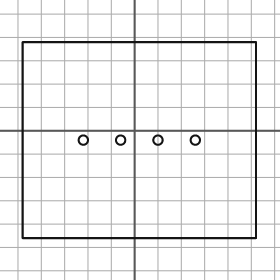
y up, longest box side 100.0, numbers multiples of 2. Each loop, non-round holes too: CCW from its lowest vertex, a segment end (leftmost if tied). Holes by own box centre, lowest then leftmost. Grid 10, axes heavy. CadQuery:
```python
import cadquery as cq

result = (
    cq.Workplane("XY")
    .moveTo(-48.0, -46.0)
    .lineTo(52.0, -46.0)
    .lineTo(52.0, 38.0)
    .lineTo(-48.0, 38.0)
    .close()
    .moveTo(-22.0, -4.0)
    .circle(2.0)
    .moveTo(-6.0, -4.0)
    .circle(2.0)
    .moveTo(10.0, -4.0)
    .circle(2.0)
    .moveTo(26.0, -4.0)
    .circle(2.0)
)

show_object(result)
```